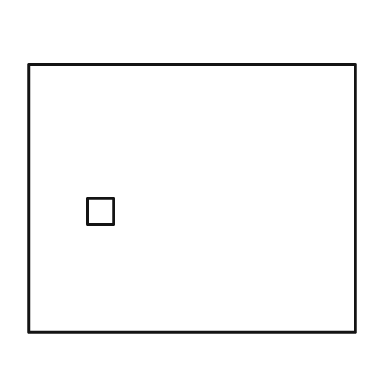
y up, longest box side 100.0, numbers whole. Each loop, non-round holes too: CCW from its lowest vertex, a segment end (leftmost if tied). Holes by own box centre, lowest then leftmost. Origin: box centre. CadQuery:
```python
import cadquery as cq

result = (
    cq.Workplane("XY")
    .moveTo(-50.0, -41.0)
    .lineTo(50.0, -41.0)
    .lineTo(50.0, 41.0)
    .lineTo(-50.0, 41.0)
    .close()
    .moveTo(-32.0, -8.0)
    .lineTo(-24.0, -8.0)
    .lineTo(-24.0, 0.0)
    .lineTo(-32.0, 0.0)
    .close()
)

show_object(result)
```